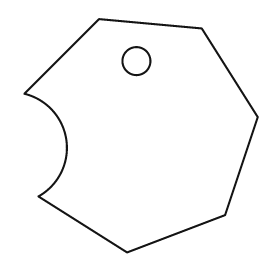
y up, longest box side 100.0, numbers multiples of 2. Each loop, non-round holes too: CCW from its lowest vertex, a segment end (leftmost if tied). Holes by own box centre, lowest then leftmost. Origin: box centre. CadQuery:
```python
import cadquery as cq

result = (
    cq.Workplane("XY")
    .moveTo(-6.0, -50.0)
    .lineTo(36.0, -34.0)
    .lineTo(50.0, 8.0)
    .lineTo(26.0, 46.0)
    .lineTo(-18.0, 50.0)
    .lineTo(-50.0, 18.0)
    .threePointArc((-32.0, -2.0), (-44.0, -26.0))
    .close()
    .moveTo(-2.0, 32.0)
    .circle(6.0)
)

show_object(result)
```